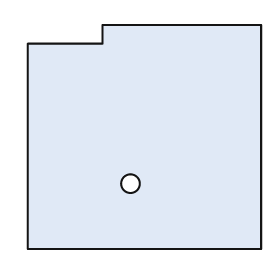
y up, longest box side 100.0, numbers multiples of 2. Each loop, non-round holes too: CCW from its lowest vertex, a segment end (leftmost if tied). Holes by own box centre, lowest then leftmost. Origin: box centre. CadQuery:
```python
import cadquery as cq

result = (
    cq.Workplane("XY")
    .moveTo(-50.0, -48.0)
    .lineTo(50.0, -48.0)
    .lineTo(50.0, 48.0)
    .lineTo(-18.0, 48.0)
    .lineTo(-18.0, 40.0)
    .lineTo(-50.0, 40.0)
    .close()
    .moveTo(-6.0, -20.0)
    .circle(4.0)
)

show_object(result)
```